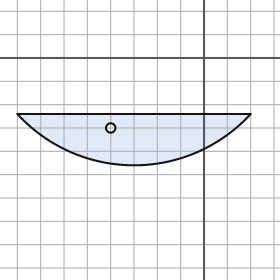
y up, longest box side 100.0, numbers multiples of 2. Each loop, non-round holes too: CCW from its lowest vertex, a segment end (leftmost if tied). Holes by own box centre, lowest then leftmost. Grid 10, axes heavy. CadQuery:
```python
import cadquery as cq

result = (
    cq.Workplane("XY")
    .moveTo(-80.0, -24.0)
    .threePointArc((-30.0, -46.0), (20.0, -24.0))
    .close()
    .moveTo(-40.0, -30.0)
    .circle(2.0)
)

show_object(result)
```